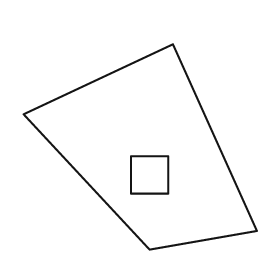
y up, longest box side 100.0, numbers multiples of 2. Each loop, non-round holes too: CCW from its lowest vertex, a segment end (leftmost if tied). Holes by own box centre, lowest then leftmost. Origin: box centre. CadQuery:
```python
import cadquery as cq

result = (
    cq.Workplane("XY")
    .moveTo(4.0, -44.0)
    .lineTo(50.0, -36.0)
    .lineTo(14.0, 44.0)
    .lineTo(-50.0, 14.0)
    .close()
    .moveTo(-4.0, -20.0)
    .lineTo(12.0, -20.0)
    .lineTo(12.0, -4.0)
    .lineTo(-4.0, -4.0)
    .close()
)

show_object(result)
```